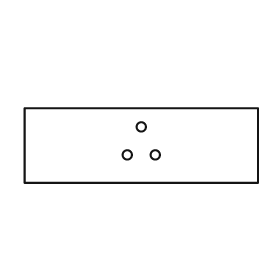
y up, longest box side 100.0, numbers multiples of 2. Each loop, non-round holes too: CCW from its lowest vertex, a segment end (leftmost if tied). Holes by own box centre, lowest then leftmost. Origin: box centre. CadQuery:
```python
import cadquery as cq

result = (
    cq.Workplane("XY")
    .moveTo(-50.0, -16.0)
    .lineTo(50.0, -16.0)
    .lineTo(50.0, 16.0)
    .lineTo(-50.0, 16.0)
    .close()
    .moveTo(-6.0, -4.0)
    .circle(2.0)
    .moveTo(6.0, -4.0)
    .circle(2.0)
    .moveTo(0.0, 8.0)
    .circle(2.0)
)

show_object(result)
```